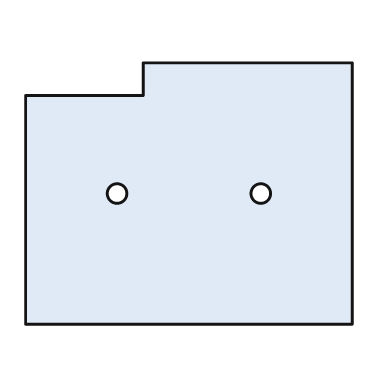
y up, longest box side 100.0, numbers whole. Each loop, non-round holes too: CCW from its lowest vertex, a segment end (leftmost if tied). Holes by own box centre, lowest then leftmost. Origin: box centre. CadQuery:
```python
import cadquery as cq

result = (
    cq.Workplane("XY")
    .moveTo(-50.0, -40.0)
    .lineTo(50.0, -40.0)
    .lineTo(50.0, 40.0)
    .lineTo(-14.0, 40.0)
    .lineTo(-14.0, 30.0)
    .lineTo(-50.0, 30.0)
    .close()
    .moveTo(-22.0, 0.0)
    .circle(3.0)
    .moveTo(22.0, 0.0)
    .circle(3.0)
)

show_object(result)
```